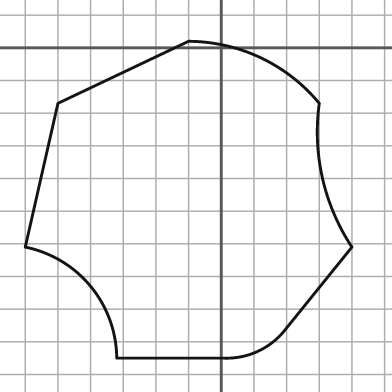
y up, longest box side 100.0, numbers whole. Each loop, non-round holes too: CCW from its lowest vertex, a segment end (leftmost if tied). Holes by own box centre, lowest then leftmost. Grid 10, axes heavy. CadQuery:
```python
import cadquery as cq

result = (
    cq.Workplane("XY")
    .moveTo(-32.0, -95.0)
    .lineTo(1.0, -95.0)
    .threePointArc((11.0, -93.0), (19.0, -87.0))
    .lineTo(40.0, -61.0)
    .threePointArc((31.0, -40.0), (30.0, -17.0))
    .threePointArc((12.0, -3.0), (-10.0, 2.0))
    .lineTo(-50.0, -17.0)
    .lineTo(-60.0, -61.0)
    .threePointArc((-40.0, -73.0), (-32.0, -95.0))
    .close()
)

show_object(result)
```